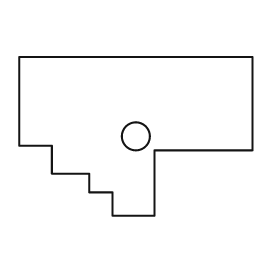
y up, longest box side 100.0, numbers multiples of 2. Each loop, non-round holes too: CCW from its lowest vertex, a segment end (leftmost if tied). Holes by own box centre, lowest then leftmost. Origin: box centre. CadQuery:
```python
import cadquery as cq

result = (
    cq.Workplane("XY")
    .moveTo(-10.0, -34.0)
    .lineTo(8.0, -34.0)
    .lineTo(8.0, -6.0)
    .lineTo(50.0, -6.0)
    .lineTo(50.0, 34.0)
    .lineTo(-50.0, 34.0)
    .lineTo(-50.0, -4.0)
    .lineTo(-36.0, -4.0)
    .lineTo(-36.0, -16.0)
    .lineTo(-20.0, -16.0)
    .lineTo(-20.0, -24.0)
    .lineTo(-10.0, -24.0)
    .close()
    .moveTo(0.0, 0.0)
    .circle(6.0)
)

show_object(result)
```